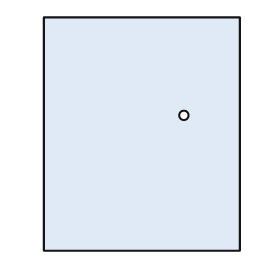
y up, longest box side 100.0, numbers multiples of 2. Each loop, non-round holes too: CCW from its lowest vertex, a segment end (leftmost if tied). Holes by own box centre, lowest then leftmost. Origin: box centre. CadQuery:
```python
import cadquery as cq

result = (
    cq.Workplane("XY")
    .moveTo(-42.0, -50.0)
    .lineTo(42.0, -50.0)
    .lineTo(42.0, 50.0)
    .lineTo(-42.0, 50.0)
    .close()
    .moveTo(18.0, 8.0)
    .circle(2.0)
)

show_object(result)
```